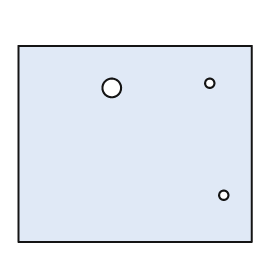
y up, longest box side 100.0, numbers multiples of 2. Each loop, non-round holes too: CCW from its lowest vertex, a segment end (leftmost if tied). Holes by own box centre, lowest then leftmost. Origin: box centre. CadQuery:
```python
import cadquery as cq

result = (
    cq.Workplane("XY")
    .moveTo(-50.0, -42.0)
    .lineTo(50.0, -42.0)
    .lineTo(50.0, 42.0)
    .lineTo(-50.0, 42.0)
    .close()
    .moveTo(38.0, -22.0)
    .circle(2.0)
    .moveTo(-10.0, 24.0)
    .circle(4.0)
    .moveTo(32.0, 26.0)
    .circle(2.0)
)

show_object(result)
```